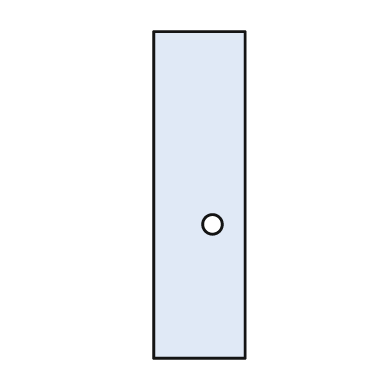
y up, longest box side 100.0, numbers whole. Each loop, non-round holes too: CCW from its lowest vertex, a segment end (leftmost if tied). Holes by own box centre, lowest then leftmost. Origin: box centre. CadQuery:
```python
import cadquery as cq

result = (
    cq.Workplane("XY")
    .moveTo(-14.0, -50.0)
    .lineTo(14.0, -50.0)
    .lineTo(14.0, 50.0)
    .lineTo(-14.0, 50.0)
    .close()
    .moveTo(4.0, -9.0)
    .circle(3.0)
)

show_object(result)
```